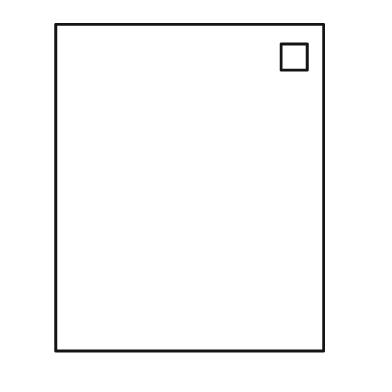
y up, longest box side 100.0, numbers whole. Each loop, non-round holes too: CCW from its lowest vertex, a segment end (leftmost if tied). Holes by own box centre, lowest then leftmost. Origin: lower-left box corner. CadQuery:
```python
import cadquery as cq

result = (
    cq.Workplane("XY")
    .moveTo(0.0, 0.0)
    .lineTo(82.0, 0.0)
    .lineTo(82.0, 100.0)
    .lineTo(0.0, 100.0)
    .close()
    .moveTo(69.0, 86.0)
    .lineTo(77.0, 86.0)
    .lineTo(77.0, 94.0)
    .lineTo(69.0, 94.0)
    .close()
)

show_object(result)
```